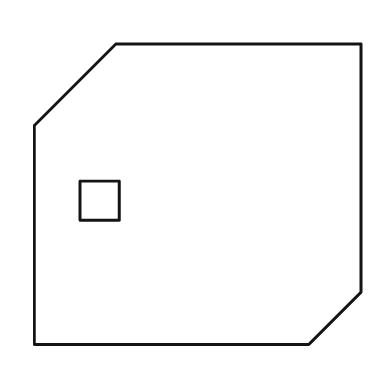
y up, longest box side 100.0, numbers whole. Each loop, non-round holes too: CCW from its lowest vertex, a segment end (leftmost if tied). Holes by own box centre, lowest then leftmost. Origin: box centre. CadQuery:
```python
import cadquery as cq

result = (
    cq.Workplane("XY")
    .moveTo(-50.0, -46.0)
    .lineTo(34.0, -46.0)
    .lineTo(50.0, -30.0)
    .lineTo(50.0, 46.0)
    .lineTo(-25.0, 46.0)
    .lineTo(-50.0, 21.0)
    .close()
    .moveTo(-36.0, -8.0)
    .lineTo(-24.0, -8.0)
    .lineTo(-24.0, 4.0)
    .lineTo(-36.0, 4.0)
    .close()
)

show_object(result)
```